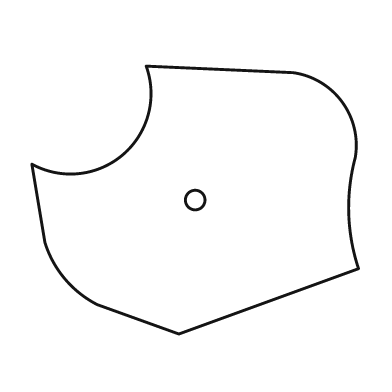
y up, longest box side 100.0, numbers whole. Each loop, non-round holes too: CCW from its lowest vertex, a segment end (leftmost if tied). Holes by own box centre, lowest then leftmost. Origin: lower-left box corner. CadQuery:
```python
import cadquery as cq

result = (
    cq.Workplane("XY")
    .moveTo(45.0, 0.0)
    .lineTo(100.0, 20.0)
    .threePointArc((97.0, 37.0), (99.0, 54.0))
    .threePointArc((95.0, 71.0), (80.0, 80.0))
    .lineTo(35.0, 82.0)
    .threePointArc((28.0, 55.0), (0.0, 52.0))
    .lineTo(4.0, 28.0)
    .threePointArc((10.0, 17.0), (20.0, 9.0))
    .close()
    .moveTo(50.0, 41.0)
    .circle(3.0)
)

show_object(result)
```